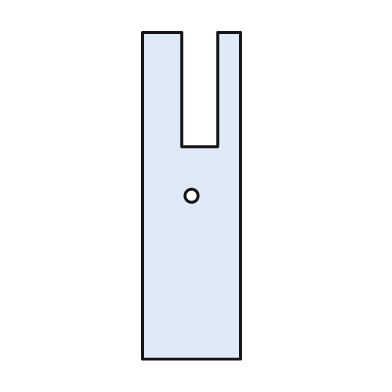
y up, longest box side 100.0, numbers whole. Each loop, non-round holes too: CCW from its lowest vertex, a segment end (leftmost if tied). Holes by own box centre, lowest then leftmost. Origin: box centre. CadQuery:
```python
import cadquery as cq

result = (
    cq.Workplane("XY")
    .moveTo(-15.0, -50.0)
    .lineTo(15.0, -50.0)
    .lineTo(15.0, 50.0)
    .lineTo(8.0, 50.0)
    .lineTo(8.0, 15.0)
    .lineTo(-3.0, 15.0)
    .lineTo(-3.0, 50.0)
    .lineTo(-15.0, 50.0)
    .close()
    .moveTo(0.0, 0.0)
    .circle(2.0)
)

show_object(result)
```